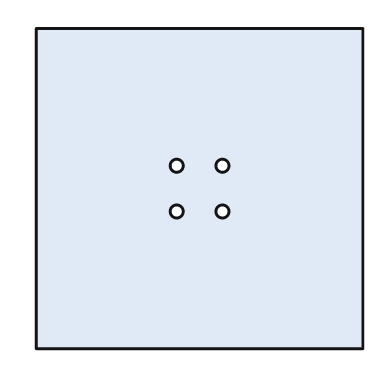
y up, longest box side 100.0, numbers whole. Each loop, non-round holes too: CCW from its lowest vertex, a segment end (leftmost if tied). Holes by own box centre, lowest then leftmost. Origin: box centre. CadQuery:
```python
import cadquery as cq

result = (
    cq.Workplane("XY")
    .moveTo(-50.0, -49.0)
    .lineTo(50.0, -49.0)
    .lineTo(50.0, 49.0)
    .lineTo(-50.0, 49.0)
    .close()
    .moveTo(-7.0, -7.0)
    .circle(2.0)
    .moveTo(7.0, -7.0)
    .circle(2.0)
    .moveTo(-7.0, 7.0)
    .circle(2.0)
    .moveTo(7.0, 7.0)
    .circle(2.0)
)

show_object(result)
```